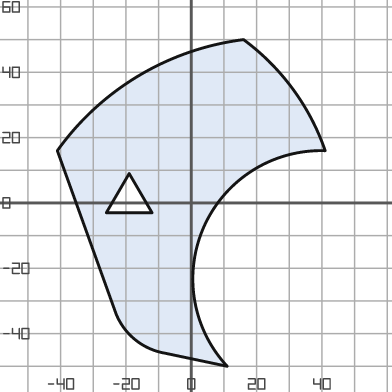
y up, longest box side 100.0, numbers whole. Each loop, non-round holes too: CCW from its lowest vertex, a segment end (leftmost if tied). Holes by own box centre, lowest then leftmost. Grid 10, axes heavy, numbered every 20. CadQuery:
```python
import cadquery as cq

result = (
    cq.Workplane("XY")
    .moveTo(11.0, -50.0)
    .threePointArc((4.0, -7.0), (41.0, 16.0))
    .threePointArc((31.0, 35.0), (16.0, 50.0))
    .threePointArc((-16.0, 39.0), (-41.0, 16.0))
    .lineTo(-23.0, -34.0)
    .threePointArc((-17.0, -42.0), (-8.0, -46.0))
    .close()
    .moveTo(-26.0, -3.0)
    .lineTo(-12.0, -3.0)
    .lineTo(-19.0, 9.0)
    .close()
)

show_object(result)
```